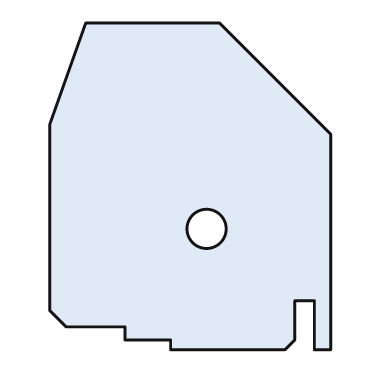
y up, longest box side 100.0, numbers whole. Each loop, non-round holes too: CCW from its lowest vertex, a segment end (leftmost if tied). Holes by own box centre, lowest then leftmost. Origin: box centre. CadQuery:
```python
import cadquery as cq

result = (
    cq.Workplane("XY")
    .moveTo(-6.0, -50.0)
    .lineTo(29.0, -50.0)
    .lineTo(32.0, -47.0)
    .lineTo(32.0, -35.0)
    .lineTo(38.0, -35.0)
    .lineTo(38.0, -50.0)
    .lineTo(43.0, -50.0)
    .lineTo(43.0, 16.0)
    .lineTo(9.0, 50.0)
    .lineTo(-32.0, 50.0)
    .lineTo(-43.0, 19.0)
    .lineTo(-43.0, -38.0)
    .lineTo(-38.0, -43.0)
    .lineTo(-20.0, -43.0)
    .lineTo(-20.0, -47.0)
    .lineTo(-6.0, -47.0)
    .close()
    .moveTo(5.0, -13.0)
    .circle(6.0)
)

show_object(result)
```